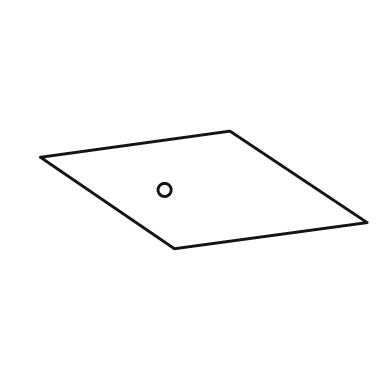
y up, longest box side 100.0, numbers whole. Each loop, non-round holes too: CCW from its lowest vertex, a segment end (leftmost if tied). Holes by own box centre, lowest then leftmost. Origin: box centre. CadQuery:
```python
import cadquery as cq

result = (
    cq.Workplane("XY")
    .moveTo(-9.0, -18.0)
    .lineTo(50.0, -10.0)
    .lineTo(8.0, 18.0)
    .lineTo(-50.0, 10.0)
    .close()
    .moveTo(-12.0, 0.0)
    .circle(2.0)
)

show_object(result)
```